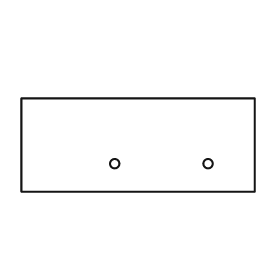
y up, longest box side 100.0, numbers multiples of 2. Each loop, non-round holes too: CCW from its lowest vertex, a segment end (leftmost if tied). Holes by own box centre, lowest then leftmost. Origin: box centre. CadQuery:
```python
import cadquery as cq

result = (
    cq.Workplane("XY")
    .moveTo(-50.0, -20.0)
    .lineTo(50.0, -20.0)
    .lineTo(50.0, 20.0)
    .lineTo(-50.0, 20.0)
    .close()
    .moveTo(-10.0, -8.0)
    .circle(2.0)
    .moveTo(30.0, -8.0)
    .circle(2.0)
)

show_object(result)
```